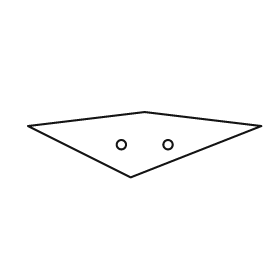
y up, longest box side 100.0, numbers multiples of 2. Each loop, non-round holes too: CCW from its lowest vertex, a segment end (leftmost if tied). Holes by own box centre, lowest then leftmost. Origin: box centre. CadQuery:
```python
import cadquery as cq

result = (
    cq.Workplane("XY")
    .moveTo(-6.0, -14.0)
    .lineTo(50.0, 8.0)
    .lineTo(0.0, 14.0)
    .lineTo(-50.0, 8.0)
    .close()
    .moveTo(-10.0, 0.0)
    .circle(2.0)
    .moveTo(10.0, 0.0)
    .circle(2.0)
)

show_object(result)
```